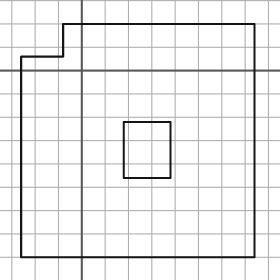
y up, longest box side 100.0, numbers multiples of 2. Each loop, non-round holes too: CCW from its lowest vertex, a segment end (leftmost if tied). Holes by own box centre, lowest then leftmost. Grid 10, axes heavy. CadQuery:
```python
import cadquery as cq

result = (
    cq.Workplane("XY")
    .moveTo(-26.0, -80.0)
    .lineTo(74.0, -80.0)
    .lineTo(74.0, 20.0)
    .lineTo(-8.0, 20.0)
    .lineTo(-8.0, 6.0)
    .lineTo(-26.0, 6.0)
    .close()
    .moveTo(18.0, -46.0)
    .lineTo(38.0, -46.0)
    .lineTo(38.0, -22.0)
    .lineTo(18.0, -22.0)
    .close()
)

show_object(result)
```